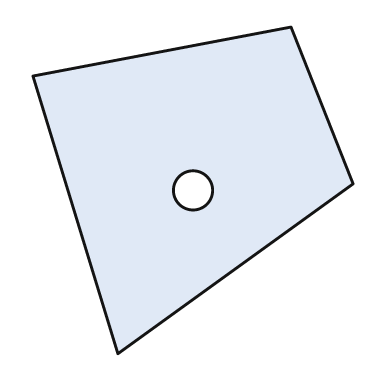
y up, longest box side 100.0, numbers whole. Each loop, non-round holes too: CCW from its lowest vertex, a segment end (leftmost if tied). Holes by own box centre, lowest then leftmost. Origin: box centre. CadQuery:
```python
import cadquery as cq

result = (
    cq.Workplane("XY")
    .moveTo(-23.0, -50.0)
    .lineTo(49.0, 2.0)
    .lineTo(30.0, 50.0)
    .lineTo(-49.0, 35.0)
    .close()
    .moveTo(0.0, 0.0)
    .circle(6.0)
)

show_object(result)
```